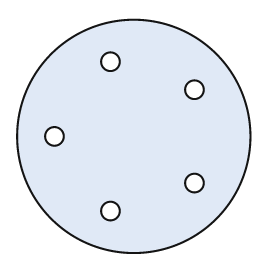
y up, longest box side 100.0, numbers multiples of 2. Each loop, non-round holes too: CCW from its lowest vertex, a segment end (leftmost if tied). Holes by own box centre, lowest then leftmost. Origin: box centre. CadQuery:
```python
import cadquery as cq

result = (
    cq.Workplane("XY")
    .moveTo(0.0, 0.0)
    .circle(50.0)
    .moveTo(-10.0, -32.0)
    .circle(4.0)
    .moveTo(26.0, -20.0)
    .circle(4.0)
    .moveTo(-34.0, 0.0)
    .circle(4.0)
    .moveTo(26.0, 20.0)
    .circle(4.0)
    .moveTo(-10.0, 32.0)
    .circle(4.0)
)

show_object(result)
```